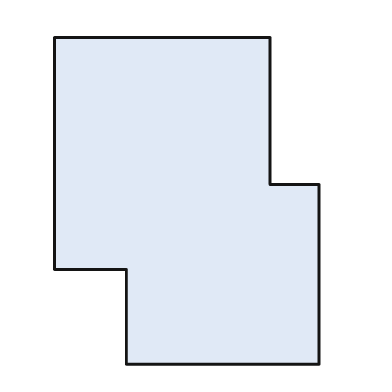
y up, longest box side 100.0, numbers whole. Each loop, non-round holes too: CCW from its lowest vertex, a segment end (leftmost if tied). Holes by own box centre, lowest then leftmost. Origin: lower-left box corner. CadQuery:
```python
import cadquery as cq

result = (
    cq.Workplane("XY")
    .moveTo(22.0, 0.0)
    .lineTo(81.0, 0.0)
    .lineTo(81.0, 55.0)
    .lineTo(66.0, 55.0)
    .lineTo(66.0, 100.0)
    .lineTo(0.0, 100.0)
    .lineTo(0.0, 29.0)
    .lineTo(22.0, 29.0)
    .close()
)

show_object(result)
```